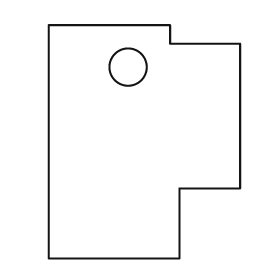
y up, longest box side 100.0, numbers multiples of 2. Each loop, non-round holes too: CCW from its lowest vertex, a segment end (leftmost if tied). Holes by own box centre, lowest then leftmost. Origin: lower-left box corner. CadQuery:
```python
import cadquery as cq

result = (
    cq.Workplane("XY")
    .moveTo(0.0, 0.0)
    .lineTo(56.0, 0.0)
    .lineTo(56.0, 30.0)
    .lineTo(82.0, 30.0)
    .lineTo(82.0, 92.0)
    .lineTo(52.0, 92.0)
    .lineTo(52.0, 100.0)
    .lineTo(0.0, 100.0)
    .close()
    .moveTo(34.0, 82.0)
    .circle(8.0)
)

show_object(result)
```